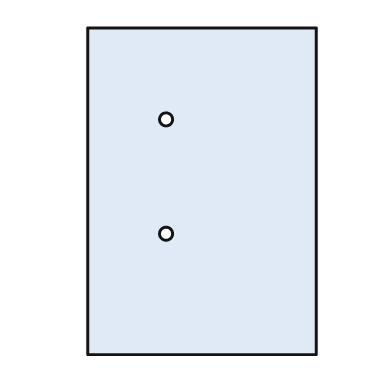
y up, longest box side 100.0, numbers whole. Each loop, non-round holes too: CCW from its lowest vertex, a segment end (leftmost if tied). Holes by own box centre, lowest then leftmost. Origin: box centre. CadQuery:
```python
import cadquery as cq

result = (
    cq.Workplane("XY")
    .moveTo(-35.0, -50.0)
    .lineTo(35.0, -50.0)
    .lineTo(35.0, 50.0)
    .lineTo(-35.0, 50.0)
    .close()
    .moveTo(-11.0, -13.0)
    .circle(2.0)
    .moveTo(-11.0, 22.0)
    .circle(2.0)
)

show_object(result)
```